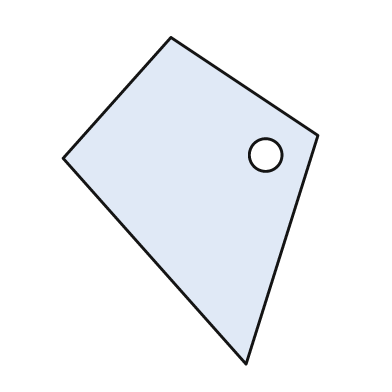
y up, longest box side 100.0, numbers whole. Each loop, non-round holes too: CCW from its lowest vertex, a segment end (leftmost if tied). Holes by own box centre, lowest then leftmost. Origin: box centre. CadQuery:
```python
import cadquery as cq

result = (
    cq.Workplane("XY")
    .moveTo(17.0, -50.0)
    .lineTo(39.0, 20.0)
    .lineTo(-6.0, 50.0)
    .lineTo(-39.0, 13.0)
    .close()
    .moveTo(23.0, 14.0)
    .circle(5.0)
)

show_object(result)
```